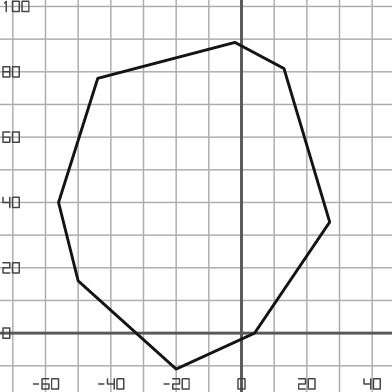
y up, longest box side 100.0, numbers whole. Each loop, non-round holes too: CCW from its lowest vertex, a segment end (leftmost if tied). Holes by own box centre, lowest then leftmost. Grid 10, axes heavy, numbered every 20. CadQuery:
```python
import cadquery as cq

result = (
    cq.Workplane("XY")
    .moveTo(-20.0, -11.0)
    .lineTo(4.0, 0.0)
    .lineTo(27.0, 34.0)
    .lineTo(13.0, 81.0)
    .lineTo(-2.0, 89.0)
    .lineTo(-44.0, 78.0)
    .lineTo(-56.0, 40.0)
    .lineTo(-50.0, 16.0)
    .close()
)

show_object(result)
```